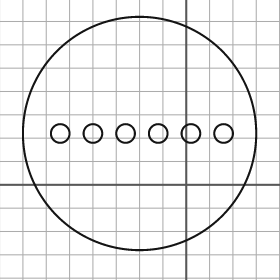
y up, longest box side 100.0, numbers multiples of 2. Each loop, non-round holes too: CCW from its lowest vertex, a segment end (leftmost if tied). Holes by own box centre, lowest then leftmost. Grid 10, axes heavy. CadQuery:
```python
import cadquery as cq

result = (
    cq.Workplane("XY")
    .moveTo(-20.0, 22.0)
    .circle(50.0)
    .moveTo(-54.0, 22.0)
    .circle(4.0)
    .moveTo(-40.0, 22.0)
    .circle(4.0)
    .moveTo(-26.0, 22.0)
    .circle(4.0)
    .moveTo(-12.0, 22.0)
    .circle(4.0)
    .moveTo(2.0, 22.0)
    .circle(4.0)
    .moveTo(16.0, 22.0)
    .circle(4.0)
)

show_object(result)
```